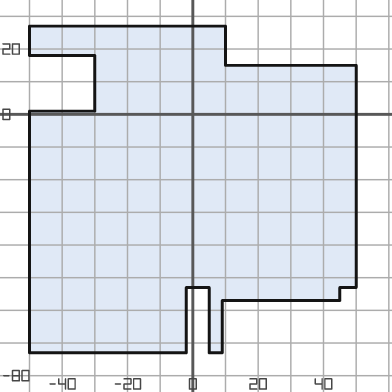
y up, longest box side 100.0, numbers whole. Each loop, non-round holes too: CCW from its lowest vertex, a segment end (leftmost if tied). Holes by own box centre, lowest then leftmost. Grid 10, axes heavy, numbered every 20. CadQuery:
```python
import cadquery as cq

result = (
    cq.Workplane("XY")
    .moveTo(-50.0, -73.0)
    .lineTo(-2.0, -73.0)
    .lineTo(-2.0, -53.0)
    .lineTo(5.0, -53.0)
    .lineTo(5.0, -73.0)
    .lineTo(9.0, -73.0)
    .lineTo(9.0, -57.0)
    .lineTo(45.0, -57.0)
    .lineTo(45.0, -53.0)
    .lineTo(50.0, -53.0)
    .lineTo(50.0, 15.0)
    .lineTo(10.0, 15.0)
    .lineTo(10.0, 27.0)
    .lineTo(-50.0, 27.0)
    .lineTo(-50.0, 18.0)
    .lineTo(-30.0, 18.0)
    .lineTo(-30.0, 1.0)
    .lineTo(-50.0, 1.0)
    .close()
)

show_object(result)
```